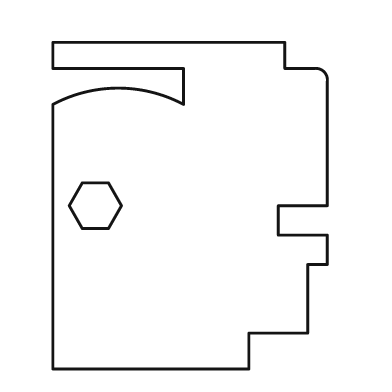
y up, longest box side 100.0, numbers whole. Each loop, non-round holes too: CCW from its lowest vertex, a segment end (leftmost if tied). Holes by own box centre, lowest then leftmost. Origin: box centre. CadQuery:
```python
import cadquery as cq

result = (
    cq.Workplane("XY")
    .moveTo(-42.0, -50.0)
    .lineTo(18.0, -50.0)
    .lineTo(18.0, -39.0)
    .lineTo(36.0, -39.0)
    .lineTo(36.0, -18.0)
    .lineTo(42.0, -18.0)
    .lineTo(42.0, -9.0)
    .lineTo(27.0, -9.0)
    .lineTo(27.0, 0.0)
    .lineTo(42.0, 0.0)
    .lineTo(42.0, 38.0)
    .threePointArc((41.0, 41.0), (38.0, 42.0))
    .lineTo(29.0, 42.0)
    .lineTo(29.0, 50.0)
    .lineTo(-42.0, 50.0)
    .lineTo(-42.0, 42.0)
    .lineTo(-2.0, 42.0)
    .lineTo(-2.0, 31.0)
    .threePointArc((-22.0, 36.0), (-42.0, 31.0))
    .close()
    .moveTo(-33.0, -7.0)
    .lineTo(-25.0, -7.0)
    .lineTo(-21.0, 0.0)
    .lineTo(-25.0, 7.0)
    .lineTo(-33.0, 7.0)
    .lineTo(-37.0, 0.0)
    .close()
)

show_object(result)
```